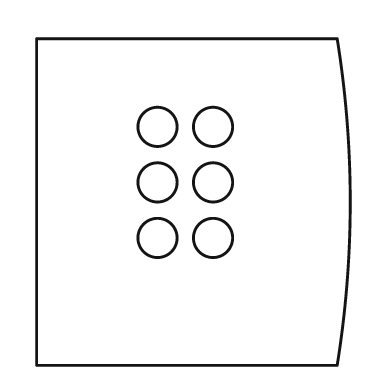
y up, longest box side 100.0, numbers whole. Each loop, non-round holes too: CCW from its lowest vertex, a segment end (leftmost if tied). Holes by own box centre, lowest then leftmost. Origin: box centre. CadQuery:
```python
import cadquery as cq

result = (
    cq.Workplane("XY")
    .moveTo(-48.0, -50.0)
    .lineTo(44.0, -50.0)
    .threePointArc((48.0, 0.0), (44.0, 50.0))
    .lineTo(-48.0, 50.0)
    .close()
    .moveTo(-11.0, -11.0)
    .circle(6.0)
    .moveTo(6.0, -11.0)
    .circle(6.0)
    .moveTo(-11.0, 6.0)
    .circle(6.0)
    .moveTo(6.0, 6.0)
    .circle(6.0)
    .moveTo(-11.0, 23.0)
    .circle(6.0)
    .moveTo(6.0, 23.0)
    .circle(6.0)
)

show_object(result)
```